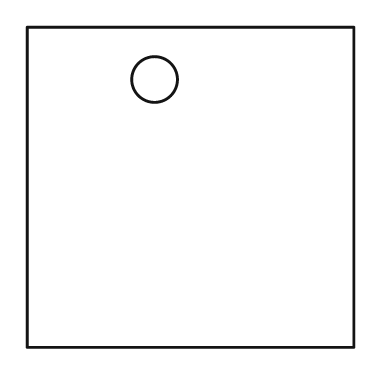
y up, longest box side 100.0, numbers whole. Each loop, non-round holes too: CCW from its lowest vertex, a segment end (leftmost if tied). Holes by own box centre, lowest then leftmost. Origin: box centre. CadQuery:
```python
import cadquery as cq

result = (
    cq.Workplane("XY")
    .moveTo(-50.0, -49.0)
    .lineTo(50.0, -49.0)
    .lineTo(50.0, 49.0)
    .lineTo(-50.0, 49.0)
    .close()
    .moveTo(-11.0, 33.0)
    .circle(7.0)
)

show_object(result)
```